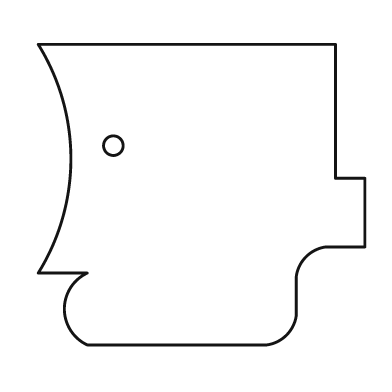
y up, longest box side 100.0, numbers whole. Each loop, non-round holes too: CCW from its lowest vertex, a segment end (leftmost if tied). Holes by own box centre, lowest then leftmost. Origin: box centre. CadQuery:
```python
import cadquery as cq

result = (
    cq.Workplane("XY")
    .moveTo(-35.0, -46.0)
    .lineTo(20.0, -46.0)
    .threePointArc((26.0, -43.0), (29.0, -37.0))
    .lineTo(29.0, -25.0)
    .threePointArc((32.0, -19.0), (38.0, -16.0))
    .lineTo(50.0, -16.0)
    .lineTo(50.0, 5.0)
    .lineTo(41.0, 5.0)
    .lineTo(41.0, 46.0)
    .lineTo(-50.0, 46.0)
    .threePointArc((-40.0, 11.0), (-50.0, -24.0))
    .lineTo(-35.0, -24.0)
    .threePointArc((-42.0, -35.0), (-35.0, -46.0))
    .close()
    .moveTo(-27.0, 15.0)
    .circle(3.0)
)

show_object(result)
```